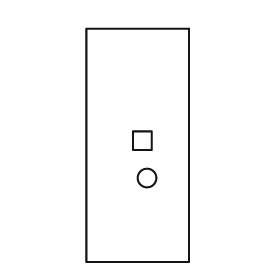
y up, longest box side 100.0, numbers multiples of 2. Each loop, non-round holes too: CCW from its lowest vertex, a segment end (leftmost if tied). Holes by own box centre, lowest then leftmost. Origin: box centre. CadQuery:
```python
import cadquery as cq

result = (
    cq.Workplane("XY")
    .moveTo(-22.0, -50.0)
    .lineTo(22.0, -50.0)
    .lineTo(22.0, 50.0)
    .lineTo(-22.0, 50.0)
    .close()
    .moveTo(4.0, -14.0)
    .circle(4.0)
    .moveTo(-2.0, -2.0)
    .lineTo(6.0, -2.0)
    .lineTo(6.0, 6.0)
    .lineTo(-2.0, 6.0)
    .close()
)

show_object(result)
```